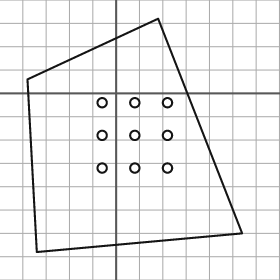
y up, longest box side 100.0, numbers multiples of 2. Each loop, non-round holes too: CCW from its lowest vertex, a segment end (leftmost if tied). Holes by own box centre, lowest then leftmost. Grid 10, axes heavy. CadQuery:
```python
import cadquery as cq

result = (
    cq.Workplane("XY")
    .moveTo(-34.0, -68.0)
    .lineTo(54.0, -60.0)
    .lineTo(18.0, 32.0)
    .lineTo(-38.0, 6.0)
    .close()
    .moveTo(-6.0, -32.0)
    .circle(2.0)
    .moveTo(8.0, -32.0)
    .circle(2.0)
    .moveTo(22.0, -32.0)
    .circle(2.0)
    .moveTo(-6.0, -18.0)
    .circle(2.0)
    .moveTo(8.0, -18.0)
    .circle(2.0)
    .moveTo(22.0, -18.0)
    .circle(2.0)
    .moveTo(-6.0, -4.0)
    .circle(2.0)
    .moveTo(8.0, -4.0)
    .circle(2.0)
    .moveTo(22.0, -4.0)
    .circle(2.0)
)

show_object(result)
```